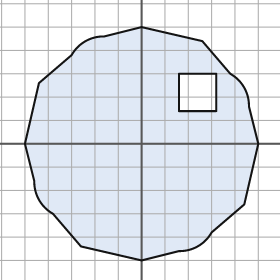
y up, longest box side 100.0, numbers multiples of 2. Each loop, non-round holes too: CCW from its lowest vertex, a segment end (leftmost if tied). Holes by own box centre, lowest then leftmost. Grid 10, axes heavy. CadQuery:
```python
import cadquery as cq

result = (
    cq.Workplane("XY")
    .moveTo(0.0, -50.0)
    .lineTo(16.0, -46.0)
    .threePointArc((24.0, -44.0), (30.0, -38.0))
    .lineTo(44.0, -26.0)
    .lineTo(50.0, 0.0)
    .lineTo(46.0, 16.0)
    .threePointArc((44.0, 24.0), (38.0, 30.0))
    .lineTo(26.0, 44.0)
    .lineTo(0.0, 50.0)
    .lineTo(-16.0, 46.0)
    .threePointArc((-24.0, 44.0), (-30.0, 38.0))
    .lineTo(-44.0, 26.0)
    .lineTo(-50.0, 0.0)
    .lineTo(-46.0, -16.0)
    .threePointArc((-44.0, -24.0), (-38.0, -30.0))
    .lineTo(-26.0, -44.0)
    .close()
    .moveTo(16.0, 14.0)
    .lineTo(32.0, 14.0)
    .lineTo(32.0, 30.0)
    .lineTo(16.0, 30.0)
    .close()
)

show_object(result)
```